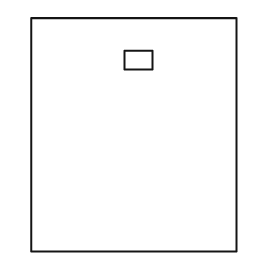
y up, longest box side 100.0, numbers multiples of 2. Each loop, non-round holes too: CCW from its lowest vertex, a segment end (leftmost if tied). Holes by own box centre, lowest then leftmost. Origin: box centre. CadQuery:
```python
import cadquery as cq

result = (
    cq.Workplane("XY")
    .moveTo(-44.0, -50.0)
    .lineTo(44.0, -50.0)
    .lineTo(44.0, 50.0)
    .lineTo(-44.0, 50.0)
    .close()
    .moveTo(-4.0, 28.0)
    .lineTo(8.0, 28.0)
    .lineTo(8.0, 36.0)
    .lineTo(-4.0, 36.0)
    .close()
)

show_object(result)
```